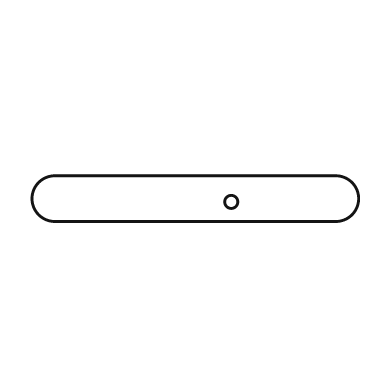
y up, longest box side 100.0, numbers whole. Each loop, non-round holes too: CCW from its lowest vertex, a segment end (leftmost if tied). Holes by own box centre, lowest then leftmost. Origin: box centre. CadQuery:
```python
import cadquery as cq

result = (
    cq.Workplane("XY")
    .moveTo(-43.0, -7.0)
    .lineTo(43.0, -7.0)
    .threePointArc((50.0, 0.0), (43.0, 7.0))
    .lineTo(-43.0, 7.0)
    .threePointArc((-50.0, 0.0), (-43.0, -7.0))
    .close()
    .moveTo(11.0, -1.0)
    .circle(2.0)
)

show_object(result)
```